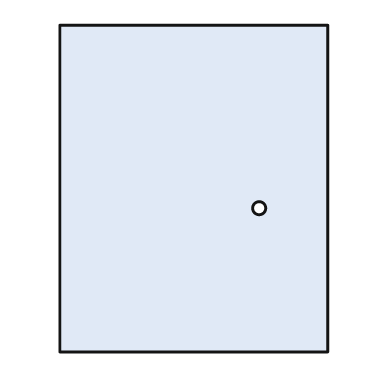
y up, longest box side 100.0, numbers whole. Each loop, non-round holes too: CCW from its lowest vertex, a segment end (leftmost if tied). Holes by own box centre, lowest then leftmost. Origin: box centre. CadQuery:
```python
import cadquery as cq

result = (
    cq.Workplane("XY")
    .moveTo(-41.0, -50.0)
    .lineTo(41.0, -50.0)
    .lineTo(41.0, 50.0)
    .lineTo(-41.0, 50.0)
    .close()
    .moveTo(20.0, -6.0)
    .circle(2.0)
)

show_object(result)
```